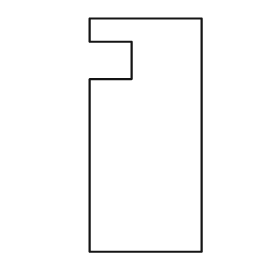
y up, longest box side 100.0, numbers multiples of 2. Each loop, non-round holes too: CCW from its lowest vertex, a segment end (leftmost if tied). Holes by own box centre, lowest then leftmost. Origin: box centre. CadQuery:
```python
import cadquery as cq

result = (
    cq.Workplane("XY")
    .moveTo(-24.0, -50.0)
    .lineTo(24.0, -50.0)
    .lineTo(24.0, 50.0)
    .lineTo(-24.0, 50.0)
    .lineTo(-24.0, 40.0)
    .lineTo(-6.0, 40.0)
    .lineTo(-6.0, 24.0)
    .lineTo(-24.0, 24.0)
    .close()
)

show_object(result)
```